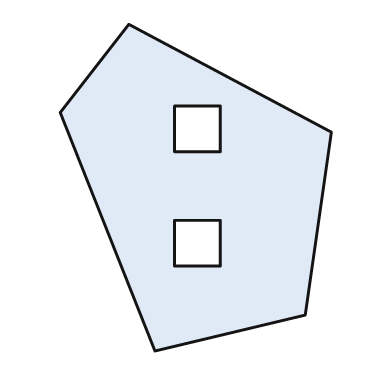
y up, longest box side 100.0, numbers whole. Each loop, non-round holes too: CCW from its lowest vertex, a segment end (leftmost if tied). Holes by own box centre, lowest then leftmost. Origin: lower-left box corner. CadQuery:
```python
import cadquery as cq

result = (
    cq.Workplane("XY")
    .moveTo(29.0, 0.0)
    .lineTo(75.0, 11.0)
    .lineTo(83.0, 67.0)
    .lineTo(21.0, 100.0)
    .lineTo(0.0, 73.0)
    .close()
    .moveTo(35.0, 26.0)
    .lineTo(49.0, 26.0)
    .lineTo(49.0, 40.0)
    .lineTo(35.0, 40.0)
    .close()
    .moveTo(35.0, 61.0)
    .lineTo(49.0, 61.0)
    .lineTo(49.0, 75.0)
    .lineTo(35.0, 75.0)
    .close()
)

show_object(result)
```